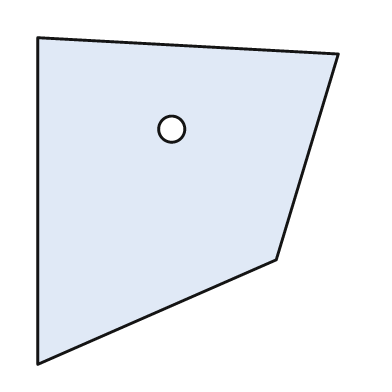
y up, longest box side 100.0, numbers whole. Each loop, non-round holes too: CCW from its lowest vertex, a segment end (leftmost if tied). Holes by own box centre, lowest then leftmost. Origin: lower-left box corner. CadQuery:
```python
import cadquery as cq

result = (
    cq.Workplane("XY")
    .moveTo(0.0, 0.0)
    .lineTo(73.0, 32.0)
    .lineTo(92.0, 95.0)
    .lineTo(0.0, 100.0)
    .close()
    .moveTo(41.0, 72.0)
    .circle(4.0)
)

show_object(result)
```